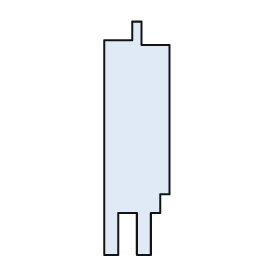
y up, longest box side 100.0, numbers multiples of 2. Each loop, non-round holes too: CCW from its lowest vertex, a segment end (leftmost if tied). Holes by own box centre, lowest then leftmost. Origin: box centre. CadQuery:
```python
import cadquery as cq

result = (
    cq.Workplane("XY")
    .moveTo(-14.0, -50.0)
    .lineTo(-8.0, -50.0)
    .lineTo(-8.0, -32.0)
    .lineTo(0.0, -32.0)
    .lineTo(0.0, -50.0)
    .lineTo(6.0, -50.0)
    .lineTo(6.0, -32.0)
    .lineTo(10.0, -32.0)
    .lineTo(10.0, -24.0)
    .lineTo(14.0, -24.0)
    .lineTo(14.0, 40.0)
    .lineTo(2.0, 40.0)
    .lineTo(2.0, 50.0)
    .lineTo(-2.0, 50.0)
    .lineTo(-2.0, 42.0)
    .lineTo(-14.0, 42.0)
    .close()
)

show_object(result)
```